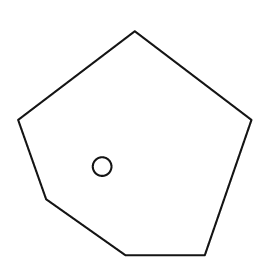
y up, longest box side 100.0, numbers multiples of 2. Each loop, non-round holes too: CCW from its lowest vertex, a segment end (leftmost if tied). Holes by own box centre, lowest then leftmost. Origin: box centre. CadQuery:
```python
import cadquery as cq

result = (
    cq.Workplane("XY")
    .moveTo(-4.0, -48.0)
    .lineTo(30.0, -48.0)
    .lineTo(50.0, 10.0)
    .lineTo(0.0, 48.0)
    .lineTo(-50.0, 10.0)
    .lineTo(-38.0, -24.0)
    .close()
    .moveTo(-14.0, -10.0)
    .circle(4.0)
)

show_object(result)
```